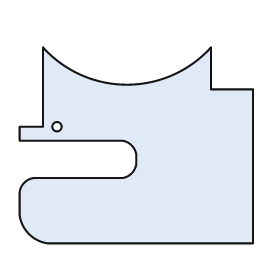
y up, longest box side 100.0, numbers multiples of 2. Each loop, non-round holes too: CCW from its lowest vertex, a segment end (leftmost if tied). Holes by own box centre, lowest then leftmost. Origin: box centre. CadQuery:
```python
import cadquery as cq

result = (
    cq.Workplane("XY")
    .moveTo(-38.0, -42.0)
    .lineTo(50.0, -42.0)
    .lineTo(50.0, 24.0)
    .lineTo(32.0, 24.0)
    .lineTo(32.0, 42.0)
    .threePointArc((-4.0, 26.0), (-40.0, 42.0))
    .lineTo(-40.0, 8.0)
    .lineTo(-50.0, 8.0)
    .lineTo(-50.0, 2.0)
    .lineTo(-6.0, 2.0)
    .threePointArc((-2.0, 0.0), (0.0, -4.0))
    .lineTo(0.0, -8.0)
    .threePointArc((-2.0, -12.0), (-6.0, -14.0))
    .lineTo(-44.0, -14.0)
    .threePointArc((-48.0, -16.0), (-50.0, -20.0))
    .lineTo(-50.0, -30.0)
    .threePointArc((-46.0, -38.0), (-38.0, -42.0))
    .close()
    .moveTo(-34.0, 8.0)
    .circle(2.0)
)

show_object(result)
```